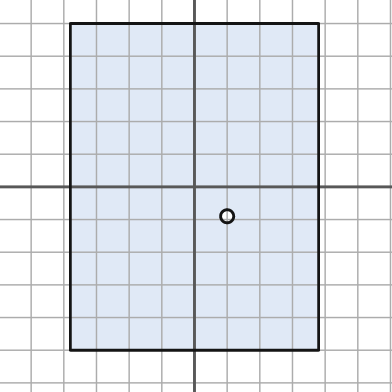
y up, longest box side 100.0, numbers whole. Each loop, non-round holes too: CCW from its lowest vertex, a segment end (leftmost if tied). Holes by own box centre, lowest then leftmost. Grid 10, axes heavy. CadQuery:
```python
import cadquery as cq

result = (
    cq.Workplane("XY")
    .moveTo(-38.0, -50.0)
    .lineTo(38.0, -50.0)
    .lineTo(38.0, 50.0)
    .lineTo(-38.0, 50.0)
    .close()
    .moveTo(10.0, -9.0)
    .circle(2.0)
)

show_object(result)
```